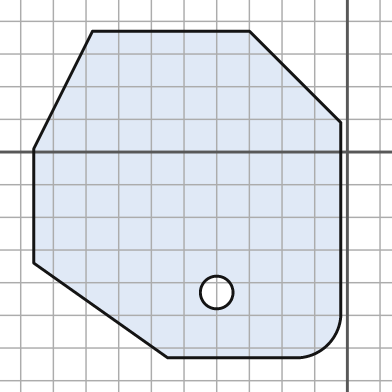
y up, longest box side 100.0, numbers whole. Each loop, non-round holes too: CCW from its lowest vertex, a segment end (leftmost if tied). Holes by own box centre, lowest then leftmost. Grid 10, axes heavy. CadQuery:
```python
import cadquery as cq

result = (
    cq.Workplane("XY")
    .moveTo(-55.0, -63.0)
    .lineTo(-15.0, -63.0)
    .threePointArc((-6.0, -59.0), (-2.0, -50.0))
    .lineTo(-2.0, 9.0)
    .lineTo(-30.0, 37.0)
    .lineTo(-78.0, 37.0)
    .lineTo(-96.0, 1.0)
    .lineTo(-96.0, -34.0)
    .close()
    .moveTo(-40.0, -43.0)
    .circle(5.0)
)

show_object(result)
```